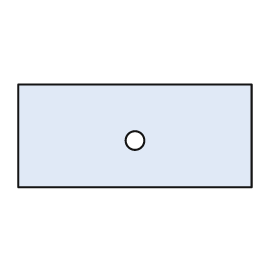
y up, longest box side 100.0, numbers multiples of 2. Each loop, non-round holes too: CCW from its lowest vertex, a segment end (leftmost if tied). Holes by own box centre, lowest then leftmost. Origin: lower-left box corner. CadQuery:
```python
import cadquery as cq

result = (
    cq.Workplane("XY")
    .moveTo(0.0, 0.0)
    .lineTo(100.0, 0.0)
    .lineTo(100.0, 44.0)
    .lineTo(0.0, 44.0)
    .close()
    .moveTo(50.0, 20.0)
    .circle(4.0)
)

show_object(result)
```